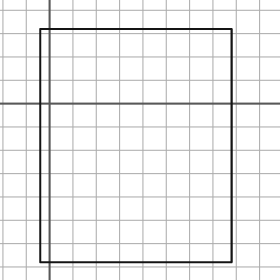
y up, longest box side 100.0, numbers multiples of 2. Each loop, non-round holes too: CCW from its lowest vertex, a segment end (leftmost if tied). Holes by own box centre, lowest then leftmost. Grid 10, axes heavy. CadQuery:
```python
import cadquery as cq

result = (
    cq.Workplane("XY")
    .moveTo(-4.0, -68.0)
    .lineTo(78.0, -68.0)
    .lineTo(78.0, 32.0)
    .lineTo(-4.0, 32.0)
    .close()
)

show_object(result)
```